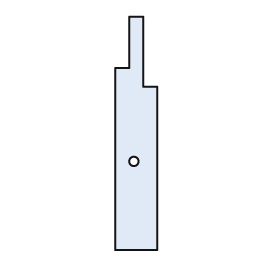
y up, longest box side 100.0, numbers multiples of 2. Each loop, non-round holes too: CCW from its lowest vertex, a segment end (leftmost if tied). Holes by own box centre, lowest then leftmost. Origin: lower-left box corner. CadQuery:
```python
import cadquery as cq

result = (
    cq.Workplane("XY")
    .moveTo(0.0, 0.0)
    .lineTo(18.0, 0.0)
    .lineTo(18.0, 70.0)
    .lineTo(12.0, 70.0)
    .lineTo(12.0, 100.0)
    .lineTo(6.0, 100.0)
    .lineTo(6.0, 78.0)
    .lineTo(0.0, 78.0)
    .close()
    .moveTo(8.0, 38.0)
    .circle(2.0)
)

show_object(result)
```